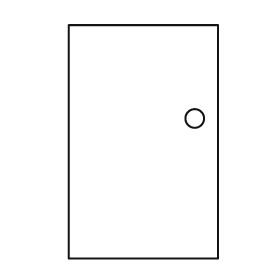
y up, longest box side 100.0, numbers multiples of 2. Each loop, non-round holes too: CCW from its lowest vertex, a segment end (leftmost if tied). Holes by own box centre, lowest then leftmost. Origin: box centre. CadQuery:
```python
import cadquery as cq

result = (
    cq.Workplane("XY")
    .moveTo(-32.0, -50.0)
    .lineTo(32.0, -50.0)
    .lineTo(32.0, 50.0)
    .lineTo(-32.0, 50.0)
    .close()
    .moveTo(22.0, 10.0)
    .circle(4.0)
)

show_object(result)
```